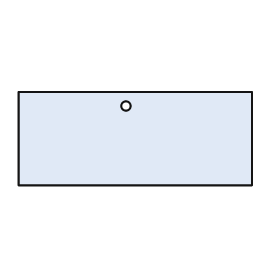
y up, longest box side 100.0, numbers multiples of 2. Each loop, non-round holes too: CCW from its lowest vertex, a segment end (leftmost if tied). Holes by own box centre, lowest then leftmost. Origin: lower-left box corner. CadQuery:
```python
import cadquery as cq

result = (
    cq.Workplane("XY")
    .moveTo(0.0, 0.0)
    .lineTo(100.0, 0.0)
    .lineTo(100.0, 40.0)
    .lineTo(0.0, 40.0)
    .close()
    .moveTo(46.0, 34.0)
    .circle(2.0)
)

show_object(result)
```